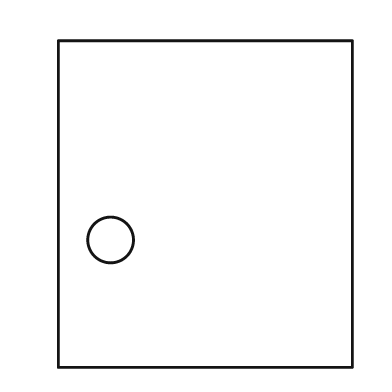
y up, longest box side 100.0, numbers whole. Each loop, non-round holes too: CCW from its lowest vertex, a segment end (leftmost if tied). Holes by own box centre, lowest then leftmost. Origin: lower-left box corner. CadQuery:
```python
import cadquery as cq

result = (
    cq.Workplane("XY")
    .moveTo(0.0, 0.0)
    .lineTo(90.0, 0.0)
    .lineTo(90.0, 100.0)
    .lineTo(0.0, 100.0)
    .close()
    .moveTo(16.0, 39.0)
    .circle(7.0)
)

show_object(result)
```